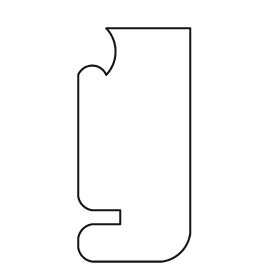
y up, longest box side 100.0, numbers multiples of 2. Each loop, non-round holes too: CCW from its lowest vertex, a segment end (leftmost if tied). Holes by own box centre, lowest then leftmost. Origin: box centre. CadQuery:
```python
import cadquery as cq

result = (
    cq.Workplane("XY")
    .moveTo(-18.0, -50.0)
    .lineTo(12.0, -50.0)
    .threePointArc((20.0, -46.0), (24.0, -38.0))
    .lineTo(24.0, 50.0)
    .lineTo(-12.0, 50.0)
    .threePointArc((-8.0, 40.0), (-12.0, 30.0))
    .threePointArc((-18.0, 34.0), (-24.0, 30.0))
    .lineTo(-24.0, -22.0)
    .threePointArc((-22.0, -26.0), (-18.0, -28.0))
    .lineTo(-6.0, -28.0)
    .lineTo(-6.0, -34.0)
    .lineTo(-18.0, -34.0)
    .threePointArc((-22.0, -36.0), (-24.0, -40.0))
    .lineTo(-24.0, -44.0)
    .threePointArc((-22.0, -48.0), (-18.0, -50.0))
    .close()
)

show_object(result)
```